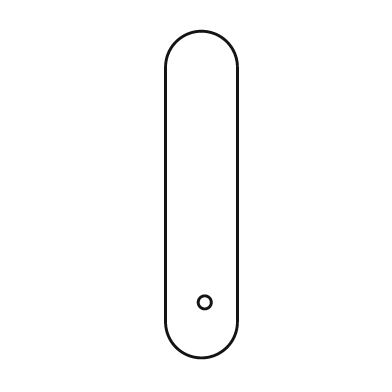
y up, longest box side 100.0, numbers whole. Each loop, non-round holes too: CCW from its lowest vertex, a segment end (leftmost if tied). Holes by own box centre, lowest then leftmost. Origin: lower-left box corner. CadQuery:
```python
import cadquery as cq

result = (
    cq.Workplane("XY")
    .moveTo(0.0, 11.0)
    .threePointArc((11.0, 0.0), (22.0, 11.0))
    .lineTo(22.0, 89.0)
    .threePointArc((11.0, 100.0), (0.0, 89.0))
    .close()
    .moveTo(12.0, 17.0)
    .circle(2.0)
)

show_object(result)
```